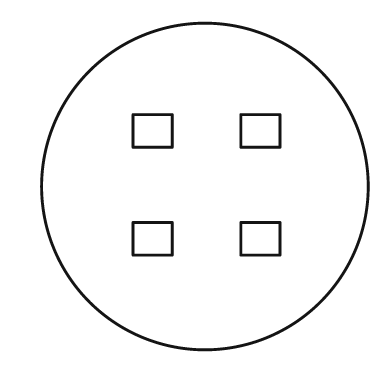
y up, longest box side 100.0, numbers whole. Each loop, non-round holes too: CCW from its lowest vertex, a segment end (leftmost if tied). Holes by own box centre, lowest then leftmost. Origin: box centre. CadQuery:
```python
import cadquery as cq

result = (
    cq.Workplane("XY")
    .moveTo(0.0, 0.0)
    .circle(50.0)
    .moveTo(-22.0, -21.0)
    .lineTo(-10.0, -21.0)
    .lineTo(-10.0, -11.0)
    .lineTo(-22.0, -11.0)
    .close()
    .moveTo(11.0, -21.0)
    .lineTo(23.0, -21.0)
    .lineTo(23.0, -11.0)
    .lineTo(11.0, -11.0)
    .close()
    .moveTo(-22.0, 12.0)
    .lineTo(-10.0, 12.0)
    .lineTo(-10.0, 22.0)
    .lineTo(-22.0, 22.0)
    .close()
    .moveTo(11.0, 12.0)
    .lineTo(23.0, 12.0)
    .lineTo(23.0, 22.0)
    .lineTo(11.0, 22.0)
    .close()
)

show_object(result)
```